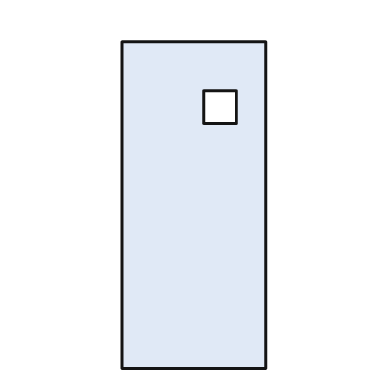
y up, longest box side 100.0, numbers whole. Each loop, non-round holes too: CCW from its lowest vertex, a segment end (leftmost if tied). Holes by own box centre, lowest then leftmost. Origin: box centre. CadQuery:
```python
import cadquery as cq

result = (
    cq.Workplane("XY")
    .moveTo(-22.0, -50.0)
    .lineTo(22.0, -50.0)
    .lineTo(22.0, 50.0)
    .lineTo(-22.0, 50.0)
    .close()
    .moveTo(3.0, 25.0)
    .lineTo(13.0, 25.0)
    .lineTo(13.0, 35.0)
    .lineTo(3.0, 35.0)
    .close()
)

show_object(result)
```